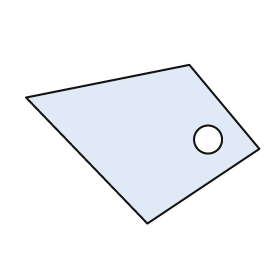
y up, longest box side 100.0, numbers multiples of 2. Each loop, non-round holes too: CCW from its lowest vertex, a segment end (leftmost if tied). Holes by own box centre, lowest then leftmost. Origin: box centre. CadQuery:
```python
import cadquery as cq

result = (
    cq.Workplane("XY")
    .moveTo(2.0, -34.0)
    .lineTo(50.0, -2.0)
    .lineTo(20.0, 34.0)
    .lineTo(-50.0, 20.0)
    .close()
    .moveTo(28.0, 2.0)
    .circle(6.0)
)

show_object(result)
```